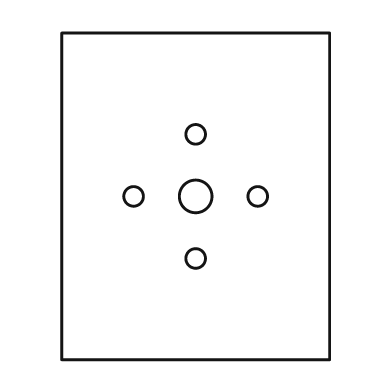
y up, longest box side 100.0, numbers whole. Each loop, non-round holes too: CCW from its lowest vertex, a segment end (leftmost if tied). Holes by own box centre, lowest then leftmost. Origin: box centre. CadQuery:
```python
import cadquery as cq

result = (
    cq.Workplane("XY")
    .moveTo(-41.0, -50.0)
    .lineTo(41.0, -50.0)
    .lineTo(41.0, 50.0)
    .lineTo(-41.0, 50.0)
    .close()
    .moveTo(0.0, -19.0)
    .circle(3.0)
    .moveTo(-19.0, 0.0)
    .circle(3.0)
    .moveTo(0.0, 0.0)
    .circle(5.0)
    .moveTo(19.0, 0.0)
    .circle(3.0)
    .moveTo(0.0, 19.0)
    .circle(3.0)
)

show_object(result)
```